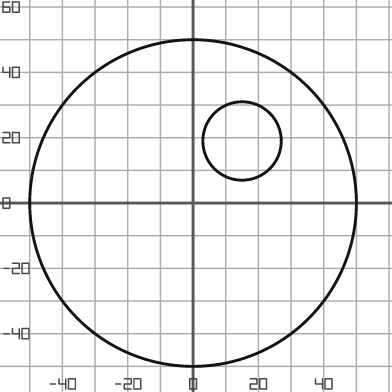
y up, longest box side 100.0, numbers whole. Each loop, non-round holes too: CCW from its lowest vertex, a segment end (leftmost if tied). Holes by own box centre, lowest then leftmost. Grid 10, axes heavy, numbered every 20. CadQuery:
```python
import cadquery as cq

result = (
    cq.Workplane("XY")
    .moveTo(0.0, 0.0)
    .circle(50.0)
    .moveTo(15.0, 19.0)
    .circle(12.0)
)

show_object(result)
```